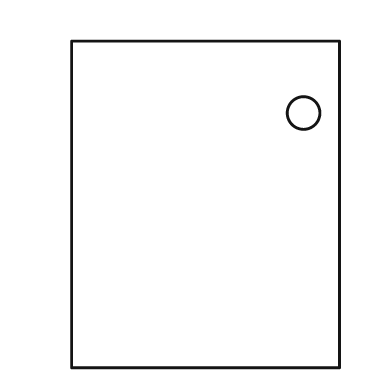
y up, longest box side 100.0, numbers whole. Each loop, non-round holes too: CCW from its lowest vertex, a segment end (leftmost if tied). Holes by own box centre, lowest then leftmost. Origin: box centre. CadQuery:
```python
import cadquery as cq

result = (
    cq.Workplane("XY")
    .moveTo(-41.0, -50.0)
    .lineTo(41.0, -50.0)
    .lineTo(41.0, 50.0)
    .lineTo(-41.0, 50.0)
    .close()
    .moveTo(30.0, 28.0)
    .circle(5.0)
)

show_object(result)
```